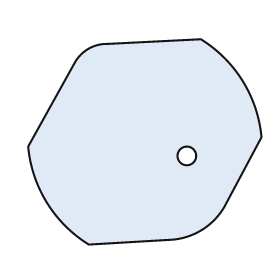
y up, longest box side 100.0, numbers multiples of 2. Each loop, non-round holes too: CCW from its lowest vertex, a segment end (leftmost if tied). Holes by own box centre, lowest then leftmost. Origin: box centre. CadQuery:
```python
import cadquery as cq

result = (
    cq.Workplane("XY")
    .moveTo(-24.0, -44.0)
    .lineTo(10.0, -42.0)
    .threePointArc((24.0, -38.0), (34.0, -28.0))
    .lineTo(50.0, 2.0)
    .threePointArc((42.0, 26.0), (24.0, 44.0))
    .lineTo(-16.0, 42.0)
    .threePointArc((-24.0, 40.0), (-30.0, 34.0))
    .lineTo(-50.0, -2.0)
    .threePointArc((-42.0, -26.0), (-24.0, -44.0))
    .close()
    .moveTo(18.0, -6.0)
    .circle(4.0)
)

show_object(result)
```